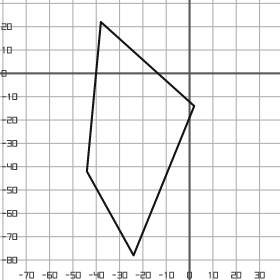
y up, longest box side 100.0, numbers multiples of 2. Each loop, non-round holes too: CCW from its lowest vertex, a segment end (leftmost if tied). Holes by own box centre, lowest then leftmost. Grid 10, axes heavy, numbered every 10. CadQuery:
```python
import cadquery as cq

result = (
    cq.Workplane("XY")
    .moveTo(-24.0, -78.0)
    .lineTo(2.0, -14.0)
    .lineTo(-38.0, 22.0)
    .lineTo(-44.0, -42.0)
    .close()
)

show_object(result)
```